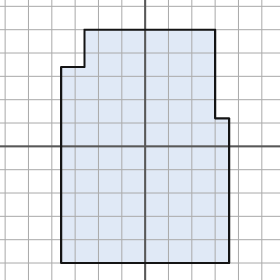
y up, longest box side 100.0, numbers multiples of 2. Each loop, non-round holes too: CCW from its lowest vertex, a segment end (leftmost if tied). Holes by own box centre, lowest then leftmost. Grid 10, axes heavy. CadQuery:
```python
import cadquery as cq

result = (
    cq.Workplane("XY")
    .moveTo(-36.0, -50.0)
    .lineTo(36.0, -50.0)
    .lineTo(36.0, 12.0)
    .lineTo(30.0, 12.0)
    .lineTo(30.0, 50.0)
    .lineTo(-26.0, 50.0)
    .lineTo(-26.0, 34.0)
    .lineTo(-36.0, 34.0)
    .close()
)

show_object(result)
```